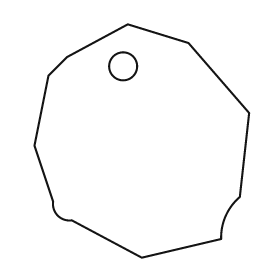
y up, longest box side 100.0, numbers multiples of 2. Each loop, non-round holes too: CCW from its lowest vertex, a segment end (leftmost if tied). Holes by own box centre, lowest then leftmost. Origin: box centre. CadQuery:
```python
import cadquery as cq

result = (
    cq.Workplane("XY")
    .moveTo(0.0, -50.0)
    .lineTo(34.0, -42.0)
    .threePointArc((36.0, -32.0), (42.0, -24.0))
    .lineTo(46.0, 12.0)
    .lineTo(20.0, 42.0)
    .lineTo(-6.0, 50.0)
    .lineTo(-32.0, 36.0)
    .lineTo(-40.0, 28.0)
    .lineTo(-46.0, -2.0)
    .lineTo(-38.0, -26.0)
    .threePointArc((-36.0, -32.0), (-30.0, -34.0))
    .close()
    .moveTo(-8.0, 32.0)
    .circle(6.0)
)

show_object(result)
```